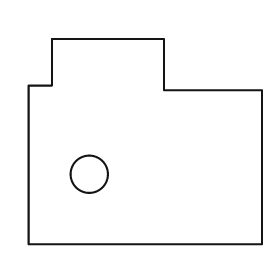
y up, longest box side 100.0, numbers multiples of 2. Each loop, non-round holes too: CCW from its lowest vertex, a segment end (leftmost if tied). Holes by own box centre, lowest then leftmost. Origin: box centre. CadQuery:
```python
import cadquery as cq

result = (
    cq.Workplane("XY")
    .moveTo(-50.0, -44.0)
    .lineTo(50.0, -44.0)
    .lineTo(50.0, 22.0)
    .lineTo(8.0, 22.0)
    .lineTo(8.0, 44.0)
    .lineTo(-40.0, 44.0)
    .lineTo(-40.0, 24.0)
    .lineTo(-50.0, 24.0)
    .close()
    .moveTo(-24.0, -14.0)
    .circle(8.0)
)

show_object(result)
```